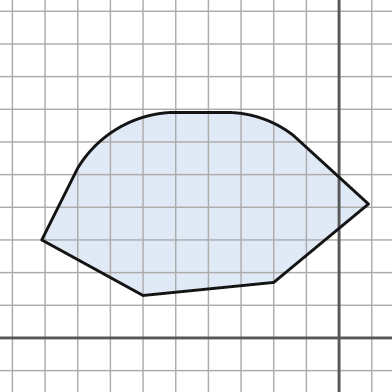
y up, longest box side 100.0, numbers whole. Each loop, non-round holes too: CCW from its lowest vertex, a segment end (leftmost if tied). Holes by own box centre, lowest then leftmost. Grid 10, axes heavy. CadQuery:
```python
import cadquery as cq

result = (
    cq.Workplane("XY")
    .moveTo(-60.0, 13.0)
    .lineTo(-20.0, 17.0)
    .lineTo(9.0, 41.0)
    .lineTo(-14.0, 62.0)
    .threePointArc((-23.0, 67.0), (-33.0, 69.0))
    .lineTo(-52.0, 69.0)
    .threePointArc((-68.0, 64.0), (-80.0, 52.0))
    .lineTo(-91.0, 30.0)
    .close()
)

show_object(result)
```